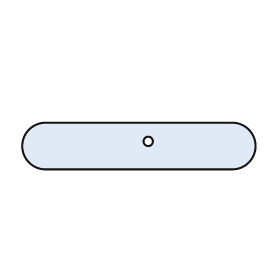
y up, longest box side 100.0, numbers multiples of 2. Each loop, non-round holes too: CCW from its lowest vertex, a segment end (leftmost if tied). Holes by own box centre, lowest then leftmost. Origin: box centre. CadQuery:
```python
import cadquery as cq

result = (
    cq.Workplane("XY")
    .moveTo(-40.0, -10.0)
    .lineTo(40.0, -10.0)
    .threePointArc((50.0, 0.0), (40.0, 10.0))
    .lineTo(-40.0, 10.0)
    .threePointArc((-50.0, 0.0), (-40.0, -10.0))
    .close()
    .moveTo(4.0, 2.0)
    .circle(2.0)
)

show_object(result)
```